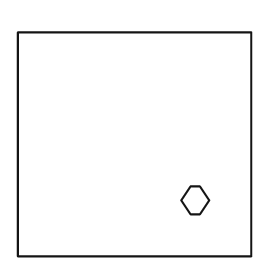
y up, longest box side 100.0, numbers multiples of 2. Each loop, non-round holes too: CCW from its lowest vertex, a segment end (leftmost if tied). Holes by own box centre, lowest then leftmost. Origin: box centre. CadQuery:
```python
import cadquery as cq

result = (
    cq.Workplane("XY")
    .moveTo(-50.0, -48.0)
    .lineTo(50.0, -48.0)
    .lineTo(50.0, 48.0)
    .lineTo(-50.0, 48.0)
    .close()
    .moveTo(24.0, -30.0)
    .lineTo(28.0, -30.0)
    .lineTo(32.0, -24.0)
    .lineTo(28.0, -18.0)
    .lineTo(24.0, -18.0)
    .lineTo(20.0, -24.0)
    .close()
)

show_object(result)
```